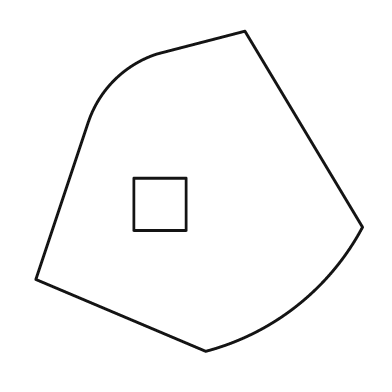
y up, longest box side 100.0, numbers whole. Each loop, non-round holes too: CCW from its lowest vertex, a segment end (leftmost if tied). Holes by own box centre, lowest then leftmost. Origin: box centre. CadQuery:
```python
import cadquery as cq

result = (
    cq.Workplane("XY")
    .moveTo(2.0, -49.0)
    .threePointArc((30.0, -35.0), (50.0, -11.0))
    .lineTo(14.0, 49.0)
    .lineTo(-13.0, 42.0)
    .threePointArc((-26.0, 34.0), (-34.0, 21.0))
    .lineTo(-50.0, -27.0)
    .close()
    .moveTo(-20.0, -12.0)
    .lineTo(-4.0, -12.0)
    .lineTo(-4.0, 4.0)
    .lineTo(-20.0, 4.0)
    .close()
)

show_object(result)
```